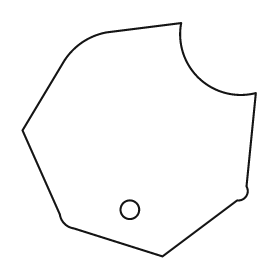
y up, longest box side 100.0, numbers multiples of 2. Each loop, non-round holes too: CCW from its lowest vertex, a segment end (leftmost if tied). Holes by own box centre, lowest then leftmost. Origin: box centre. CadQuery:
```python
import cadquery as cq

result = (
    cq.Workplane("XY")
    .moveTo(10.0, -50.0)
    .lineTo(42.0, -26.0)
    .threePointArc((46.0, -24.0), (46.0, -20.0))
    .lineTo(50.0, 20.0)
    .threePointArc((26.0, 26.0), (18.0, 50.0))
    .lineTo(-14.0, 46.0)
    .threePointArc((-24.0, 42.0), (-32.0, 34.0))
    .lineTo(-50.0, 4.0)
    .lineTo(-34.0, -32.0)
    .threePointArc((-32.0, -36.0), (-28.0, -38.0))
    .close()
    .moveTo(-4.0, -30.0)
    .circle(4.0)
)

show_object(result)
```